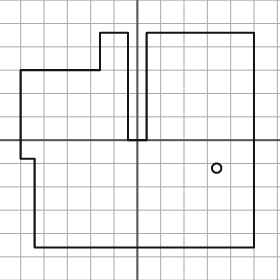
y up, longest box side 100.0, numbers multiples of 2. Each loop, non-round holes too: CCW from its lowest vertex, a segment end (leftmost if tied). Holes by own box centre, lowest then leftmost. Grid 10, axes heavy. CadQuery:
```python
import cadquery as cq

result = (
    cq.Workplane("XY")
    .moveTo(-44.0, -46.0)
    .lineTo(50.0, -46.0)
    .lineTo(50.0, 46.0)
    .lineTo(4.0, 46.0)
    .lineTo(4.0, 0.0)
    .lineTo(-4.0, 0.0)
    .lineTo(-4.0, 46.0)
    .lineTo(-16.0, 46.0)
    .lineTo(-16.0, 30.0)
    .lineTo(-50.0, 30.0)
    .lineTo(-50.0, -8.0)
    .lineTo(-44.0, -8.0)
    .close()
    .moveTo(34.0, -12.0)
    .circle(2.0)
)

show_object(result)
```